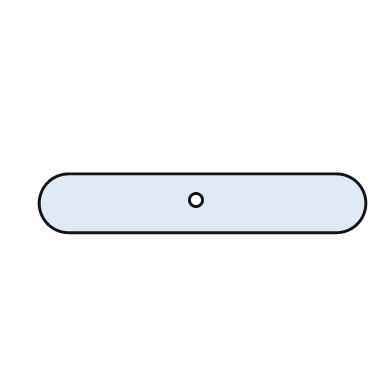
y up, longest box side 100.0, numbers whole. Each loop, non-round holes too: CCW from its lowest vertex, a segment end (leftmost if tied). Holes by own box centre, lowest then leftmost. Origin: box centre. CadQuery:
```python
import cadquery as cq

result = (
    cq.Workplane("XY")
    .moveTo(-41.0, -9.0)
    .lineTo(41.0, -9.0)
    .threePointArc((50.0, 0.0), (41.0, 9.0))
    .lineTo(-41.0, 9.0)
    .threePointArc((-50.0, 0.0), (-41.0, -9.0))
    .close()
    .moveTo(-2.0, 1.0)
    .circle(2.0)
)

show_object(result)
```